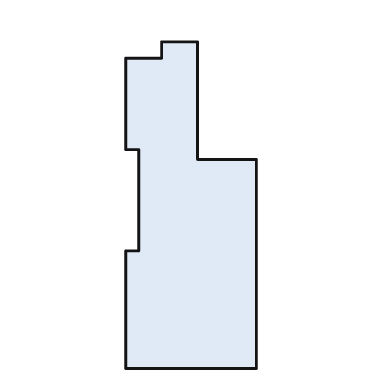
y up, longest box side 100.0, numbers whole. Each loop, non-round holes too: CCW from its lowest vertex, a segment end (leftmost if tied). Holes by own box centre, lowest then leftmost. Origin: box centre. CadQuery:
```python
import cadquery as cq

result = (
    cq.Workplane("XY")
    .moveTo(-20.0, -50.0)
    .lineTo(20.0, -50.0)
    .lineTo(20.0, 14.0)
    .lineTo(2.0, 14.0)
    .lineTo(2.0, 50.0)
    .lineTo(-9.0, 50.0)
    .lineTo(-9.0, 45.0)
    .lineTo(-20.0, 45.0)
    .lineTo(-20.0, 17.0)
    .lineTo(-16.0, 17.0)
    .lineTo(-16.0, -14.0)
    .lineTo(-20.0, -14.0)
    .close()
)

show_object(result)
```